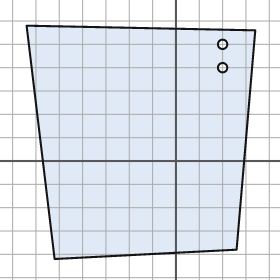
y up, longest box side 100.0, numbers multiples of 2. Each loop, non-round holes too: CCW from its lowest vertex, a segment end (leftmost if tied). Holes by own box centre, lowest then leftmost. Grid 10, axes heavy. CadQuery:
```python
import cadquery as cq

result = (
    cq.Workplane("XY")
    .moveTo(-52.0, -42.0)
    .lineTo(26.0, -38.0)
    .lineTo(34.0, 56.0)
    .lineTo(-64.0, 58.0)
    .close()
    .moveTo(20.0, 40.0)
    .circle(2.0)
    .moveTo(20.0, 50.0)
    .circle(2.0)
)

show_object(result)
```